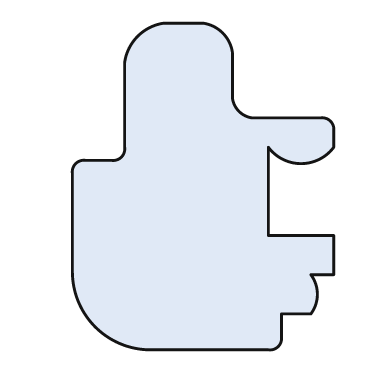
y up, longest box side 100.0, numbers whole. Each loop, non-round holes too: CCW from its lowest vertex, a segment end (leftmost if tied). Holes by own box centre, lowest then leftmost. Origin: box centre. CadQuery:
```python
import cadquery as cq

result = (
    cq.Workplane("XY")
    .moveTo(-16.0, -50.0)
    .lineTo(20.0, -50.0)
    .threePointArc((23.0, -49.0), (24.0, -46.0))
    .lineTo(24.0, -39.0)
    .lineTo(33.0, -39.0)
    .threePointArc((35.0, -33.0), (33.0, -27.0))
    .lineTo(40.0, -27.0)
    .lineTo(40.0, -15.0)
    .lineTo(20.0, -15.0)
    .lineTo(20.0, 12.0)
    .threePointArc((30.0, 7.0), (40.0, 12.0))
    .lineTo(40.0, 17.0)
    .threePointArc((39.0, 20.0), (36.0, 21.0))
    .lineTo(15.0, 21.0)
    .threePointArc((11.0, 23.0), (9.0, 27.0))
    .lineTo(9.0, 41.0)
    .threePointArc((6.0, 47.0), (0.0, 50.0))
    .lineTo(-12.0, 50.0)
    .threePointArc((-20.0, 46.0), (-24.0, 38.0))
    .lineTo(-24.0, 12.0)
    .threePointArc((-25.0, 9.0), (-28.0, 8.0))
    .lineTo(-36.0, 8.0)
    .threePointArc((-39.0, 7.0), (-40.0, 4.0))
    .lineTo(-40.0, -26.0)
    .threePointArc((-33.0, -43.0), (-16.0, -50.0))
    .close()
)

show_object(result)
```